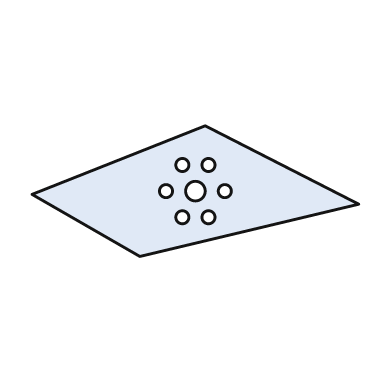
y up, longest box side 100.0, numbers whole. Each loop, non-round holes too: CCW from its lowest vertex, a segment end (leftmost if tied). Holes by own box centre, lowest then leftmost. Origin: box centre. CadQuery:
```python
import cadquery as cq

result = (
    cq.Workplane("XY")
    .moveTo(-17.0, -20.0)
    .lineTo(50.0, -4.0)
    .lineTo(3.0, 20.0)
    .lineTo(-50.0, -1.0)
    .close()
    .moveTo(-4.0, -8.0)
    .circle(2.0)
    .moveTo(4.0, -8.0)
    .circle(2.0)
    .moveTo(-9.0, 0.0)
    .circle(2.0)
    .moveTo(0.0, 0.0)
    .circle(3.0)
    .moveTo(9.0, 0.0)
    .circle(2.0)
    .moveTo(-4.0, 8.0)
    .circle(2.0)
    .moveTo(4.0, 8.0)
    .circle(2.0)
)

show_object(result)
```